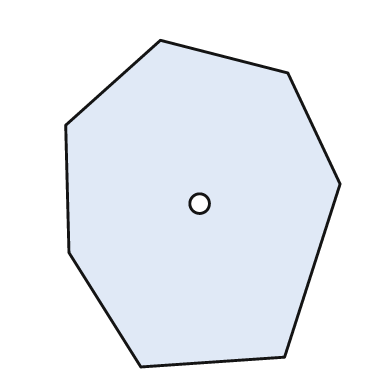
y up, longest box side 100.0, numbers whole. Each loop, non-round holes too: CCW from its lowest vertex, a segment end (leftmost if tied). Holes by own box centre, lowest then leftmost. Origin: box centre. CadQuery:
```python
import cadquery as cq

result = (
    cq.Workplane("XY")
    .moveTo(-19.0, -50.0)
    .lineTo(25.0, -47.0)
    .lineTo(42.0, 6.0)
    .lineTo(26.0, 40.0)
    .lineTo(-13.0, 50.0)
    .lineTo(-42.0, 24.0)
    .lineTo(-41.0, -15.0)
    .close()
    .moveTo(-1.0, 0.0)
    .circle(3.0)
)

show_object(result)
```